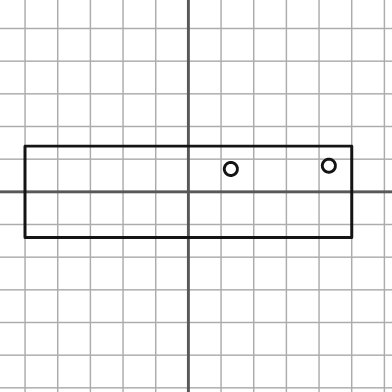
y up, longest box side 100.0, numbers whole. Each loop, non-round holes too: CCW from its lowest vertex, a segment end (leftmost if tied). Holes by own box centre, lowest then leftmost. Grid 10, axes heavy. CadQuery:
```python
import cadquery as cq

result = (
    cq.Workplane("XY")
    .moveTo(-50.0, -14.0)
    .lineTo(50.0, -14.0)
    .lineTo(50.0, 14.0)
    .lineTo(-50.0, 14.0)
    .close()
    .moveTo(13.0, 7.0)
    .circle(2.0)
    .moveTo(43.0, 8.0)
    .circle(2.0)
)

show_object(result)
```